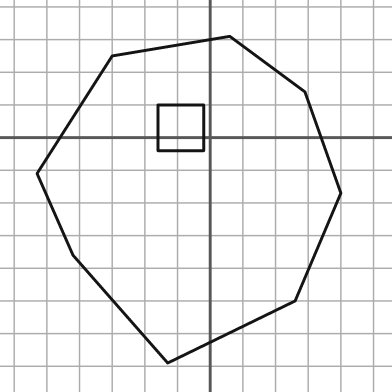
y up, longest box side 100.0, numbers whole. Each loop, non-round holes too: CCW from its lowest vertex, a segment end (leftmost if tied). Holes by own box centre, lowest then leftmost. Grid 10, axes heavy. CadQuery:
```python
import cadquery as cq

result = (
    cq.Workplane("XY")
    .moveTo(-13.0, -69.0)
    .lineTo(26.0, -50.0)
    .lineTo(40.0, -17.0)
    .lineTo(29.0, 14.0)
    .lineTo(6.0, 31.0)
    .lineTo(-30.0, 25.0)
    .lineTo(-53.0, -11.0)
    .lineTo(-42.0, -36.0)
    .close()
    .moveTo(-16.0, -4.0)
    .lineTo(-2.0, -4.0)
    .lineTo(-2.0, 10.0)
    .lineTo(-16.0, 10.0)
    .close()
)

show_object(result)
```